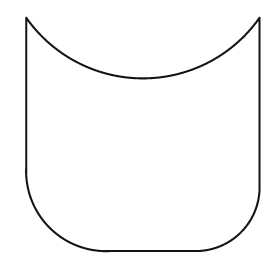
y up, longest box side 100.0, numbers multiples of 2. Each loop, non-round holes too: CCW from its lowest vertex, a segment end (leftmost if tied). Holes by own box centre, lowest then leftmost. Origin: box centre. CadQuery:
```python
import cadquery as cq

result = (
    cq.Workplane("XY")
    .moveTo(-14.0, -50.0)
    .lineTo(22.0, -50.0)
    .threePointArc((42.0, -42.0), (50.0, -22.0))
    .lineTo(50.0, 50.0)
    .threePointArc((0.0, 24.0), (-50.0, 50.0))
    .lineTo(-50.0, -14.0)
    .threePointArc((-40.0, -40.0), (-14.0, -50.0))
    .close()
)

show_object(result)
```